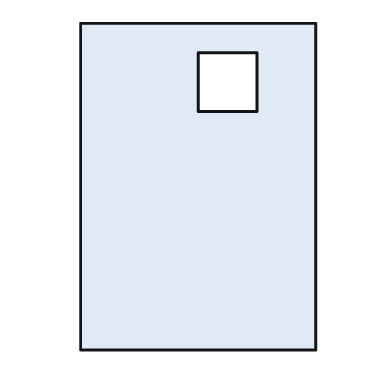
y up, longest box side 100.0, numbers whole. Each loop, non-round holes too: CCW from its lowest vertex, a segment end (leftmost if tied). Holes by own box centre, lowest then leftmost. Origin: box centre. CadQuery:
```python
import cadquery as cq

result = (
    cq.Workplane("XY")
    .moveTo(-36.0, -50.0)
    .lineTo(36.0, -50.0)
    .lineTo(36.0, 50.0)
    .lineTo(-36.0, 50.0)
    .close()
    .moveTo(0.0, 23.0)
    .lineTo(18.0, 23.0)
    .lineTo(18.0, 41.0)
    .lineTo(0.0, 41.0)
    .close()
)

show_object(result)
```